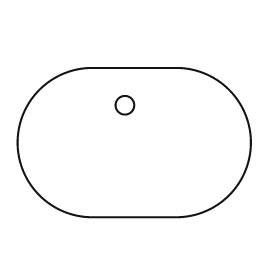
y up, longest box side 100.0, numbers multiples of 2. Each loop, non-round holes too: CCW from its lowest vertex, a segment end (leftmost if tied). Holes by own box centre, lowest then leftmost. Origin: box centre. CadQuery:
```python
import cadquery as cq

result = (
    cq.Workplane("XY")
    .moveTo(-18.0, -32.0)
    .lineTo(18.0, -32.0)
    .threePointArc((50.0, 0.0), (18.0, 32.0))
    .lineTo(-18.0, 32.0)
    .threePointArc((-50.0, 0.0), (-18.0, -32.0))
    .close()
    .moveTo(-4.0, 16.0)
    .circle(4.0)
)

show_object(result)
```